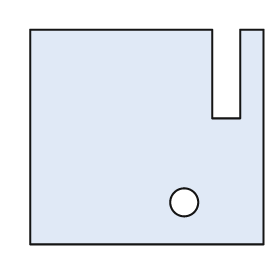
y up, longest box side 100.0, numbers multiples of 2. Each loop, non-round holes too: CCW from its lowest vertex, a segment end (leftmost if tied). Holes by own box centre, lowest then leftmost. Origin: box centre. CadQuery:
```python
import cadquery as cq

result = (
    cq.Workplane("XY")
    .moveTo(-50.0, -46.0)
    .lineTo(50.0, -46.0)
    .lineTo(50.0, 46.0)
    .lineTo(40.0, 46.0)
    .lineTo(40.0, 8.0)
    .lineTo(28.0, 8.0)
    .lineTo(28.0, 46.0)
    .lineTo(-50.0, 46.0)
    .close()
    .moveTo(16.0, -28.0)
    .circle(6.0)
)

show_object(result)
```